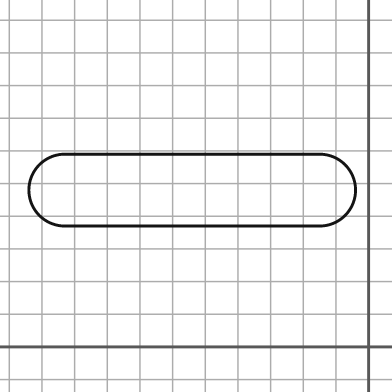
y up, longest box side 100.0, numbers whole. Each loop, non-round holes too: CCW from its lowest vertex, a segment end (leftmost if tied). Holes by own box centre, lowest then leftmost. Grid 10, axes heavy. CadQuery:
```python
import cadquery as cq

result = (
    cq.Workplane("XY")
    .moveTo(-93.0, 37.0)
    .lineTo(-15.0, 37.0)
    .threePointArc((-4.0, 48.0), (-15.0, 59.0))
    .lineTo(-93.0, 59.0)
    .threePointArc((-104.0, 48.0), (-93.0, 37.0))
    .close()
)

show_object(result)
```